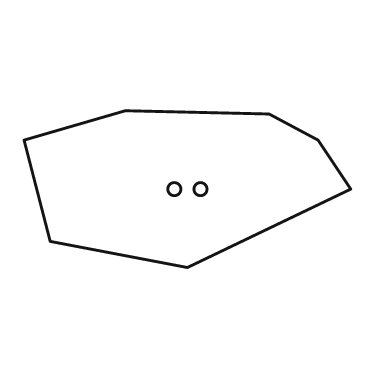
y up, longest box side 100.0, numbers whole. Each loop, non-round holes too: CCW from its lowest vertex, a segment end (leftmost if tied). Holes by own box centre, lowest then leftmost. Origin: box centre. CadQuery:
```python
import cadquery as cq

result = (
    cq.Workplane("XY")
    .moveTo(0.0, -24.0)
    .lineTo(50.0, 0.0)
    .lineTo(40.0, 15.0)
    .lineTo(25.0, 23.0)
    .lineTo(-19.0, 24.0)
    .lineTo(-50.0, 15.0)
    .lineTo(-42.0, -16.0)
    .close()
    .moveTo(-4.0, 0.0)
    .circle(2.0)
    .moveTo(4.0, 0.0)
    .circle(2.0)
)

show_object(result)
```